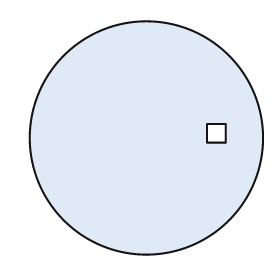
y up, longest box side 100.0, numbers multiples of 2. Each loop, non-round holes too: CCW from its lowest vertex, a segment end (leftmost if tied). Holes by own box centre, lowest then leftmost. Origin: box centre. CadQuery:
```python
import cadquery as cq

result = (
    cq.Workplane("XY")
    .moveTo(0.0, 0.0)
    .circle(50.0)
    .moveTo(26.0, -2.0)
    .lineTo(34.0, -2.0)
    .lineTo(34.0, 6.0)
    .lineTo(26.0, 6.0)
    .close()
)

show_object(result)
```